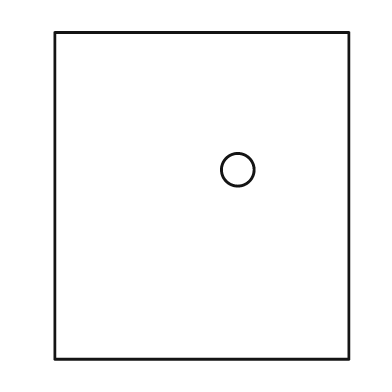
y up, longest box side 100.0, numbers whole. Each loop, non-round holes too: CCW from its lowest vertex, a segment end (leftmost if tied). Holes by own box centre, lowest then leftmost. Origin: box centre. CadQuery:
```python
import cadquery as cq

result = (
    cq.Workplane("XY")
    .moveTo(-45.0, -50.0)
    .lineTo(45.0, -50.0)
    .lineTo(45.0, 50.0)
    .lineTo(-45.0, 50.0)
    .close()
    .moveTo(11.0, 8.0)
    .circle(5.0)
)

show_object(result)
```